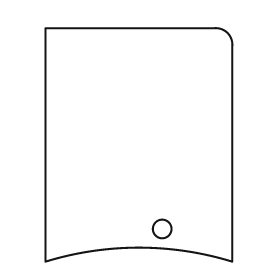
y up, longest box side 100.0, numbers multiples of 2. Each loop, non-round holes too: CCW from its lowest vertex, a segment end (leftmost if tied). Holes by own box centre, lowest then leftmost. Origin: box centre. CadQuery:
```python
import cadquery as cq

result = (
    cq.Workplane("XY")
    .moveTo(-40.0, -50.0)
    .threePointArc((0.0, -44.0), (40.0, -50.0))
    .lineTo(40.0, 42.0)
    .threePointArc((38.0, 48.0), (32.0, 50.0))
    .lineTo(-40.0, 50.0)
    .close()
    .moveTo(10.0, -36.0)
    .circle(4.0)
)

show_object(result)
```